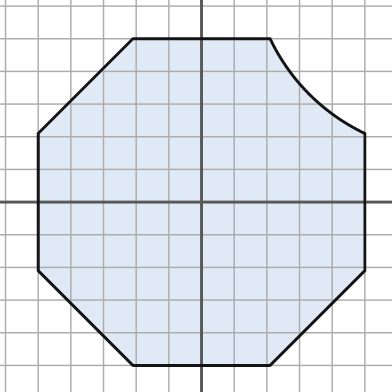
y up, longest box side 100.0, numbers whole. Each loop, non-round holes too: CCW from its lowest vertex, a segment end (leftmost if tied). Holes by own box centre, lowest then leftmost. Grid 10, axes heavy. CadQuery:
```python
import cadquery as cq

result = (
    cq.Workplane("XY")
    .moveTo(-21.0, -50.0)
    .lineTo(21.0, -50.0)
    .lineTo(50.0, -21.0)
    .lineTo(50.0, 21.0)
    .threePointArc((33.0, 33.0), (21.0, 50.0))
    .lineTo(-21.0, 50.0)
    .lineTo(-50.0, 21.0)
    .lineTo(-50.0, -21.0)
    .close()
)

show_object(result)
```